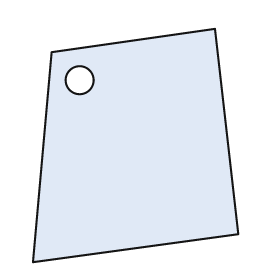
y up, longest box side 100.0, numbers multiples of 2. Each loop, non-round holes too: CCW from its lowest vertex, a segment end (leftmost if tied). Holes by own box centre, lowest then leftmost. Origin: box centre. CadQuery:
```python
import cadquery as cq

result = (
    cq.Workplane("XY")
    .moveTo(-44.0, -50.0)
    .lineTo(44.0, -38.0)
    .lineTo(34.0, 50.0)
    .lineTo(-36.0, 40.0)
    .close()
    .moveTo(-24.0, 28.0)
    .circle(6.0)
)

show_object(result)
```